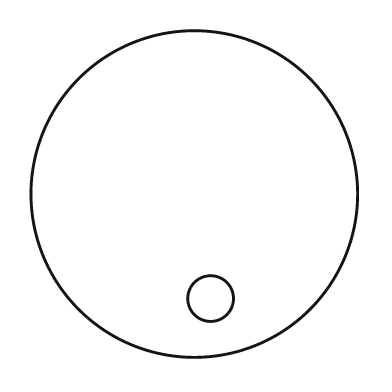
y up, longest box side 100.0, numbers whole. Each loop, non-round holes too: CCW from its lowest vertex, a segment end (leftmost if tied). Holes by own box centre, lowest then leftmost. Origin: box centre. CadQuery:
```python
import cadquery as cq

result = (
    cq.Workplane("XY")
    .moveTo(0.0, 0.0)
    .circle(50.0)
    .moveTo(5.0, -32.0)
    .circle(7.0)
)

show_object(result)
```